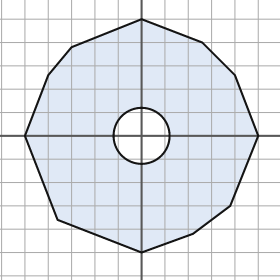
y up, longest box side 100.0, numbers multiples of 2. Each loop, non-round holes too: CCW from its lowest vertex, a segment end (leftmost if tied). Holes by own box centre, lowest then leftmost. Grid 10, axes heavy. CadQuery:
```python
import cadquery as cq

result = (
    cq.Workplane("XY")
    .moveTo(0.0, -50.0)
    .lineTo(22.0, -42.0)
    .lineTo(38.0, -30.0)
    .lineTo(50.0, 0.0)
    .lineTo(40.0, 26.0)
    .lineTo(26.0, 40.0)
    .lineTo(0.0, 50.0)
    .lineTo(-30.0, 38.0)
    .lineTo(-40.0, 26.0)
    .lineTo(-50.0, 0.0)
    .lineTo(-36.0, -36.0)
    .close()
    .moveTo(0.0, 0.0)
    .circle(12.0)
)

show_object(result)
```